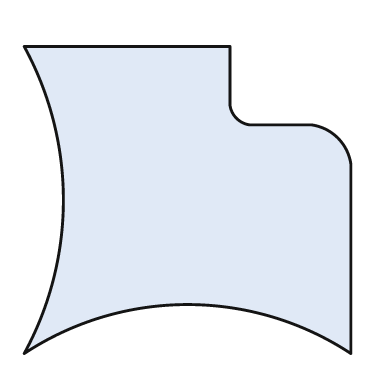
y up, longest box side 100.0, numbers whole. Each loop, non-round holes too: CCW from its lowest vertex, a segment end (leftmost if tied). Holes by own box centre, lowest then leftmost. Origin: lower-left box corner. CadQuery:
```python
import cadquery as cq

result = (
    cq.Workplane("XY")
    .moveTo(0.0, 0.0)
    .threePointArc((50.0, 15.0), (100.0, 0.0))
    .lineTo(100.0, 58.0)
    .threePointArc((96.0, 66.0), (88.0, 70.0))
    .lineTo(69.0, 70.0)
    .threePointArc((65.0, 72.0), (63.0, 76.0))
    .lineTo(63.0, 94.0)
    .lineTo(0.0, 94.0)
    .threePointArc((12.0, 47.0), (0.0, 0.0))
    .close()
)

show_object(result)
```